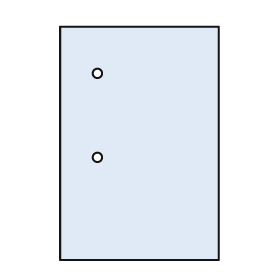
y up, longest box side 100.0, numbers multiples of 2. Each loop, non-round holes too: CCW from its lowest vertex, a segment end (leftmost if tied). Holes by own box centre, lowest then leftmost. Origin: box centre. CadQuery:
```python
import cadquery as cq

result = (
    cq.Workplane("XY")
    .moveTo(-34.0, -50.0)
    .lineTo(34.0, -50.0)
    .lineTo(34.0, 50.0)
    .lineTo(-34.0, 50.0)
    .close()
    .moveTo(-18.0, -6.0)
    .circle(2.0)
    .moveTo(-18.0, 30.0)
    .circle(2.0)
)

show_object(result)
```